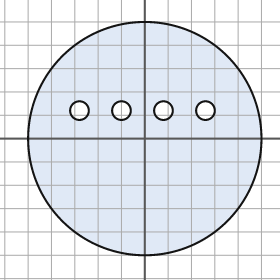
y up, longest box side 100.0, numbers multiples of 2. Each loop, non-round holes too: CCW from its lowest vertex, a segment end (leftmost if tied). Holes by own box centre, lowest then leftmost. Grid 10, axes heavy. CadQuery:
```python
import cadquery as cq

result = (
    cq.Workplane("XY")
    .moveTo(0.0, 0.0)
    .circle(50.0)
    .moveTo(-28.0, 12.0)
    .circle(4.0)
    .moveTo(-10.0, 12.0)
    .circle(4.0)
    .moveTo(8.0, 12.0)
    .circle(4.0)
    .moveTo(26.0, 12.0)
    .circle(4.0)
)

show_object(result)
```